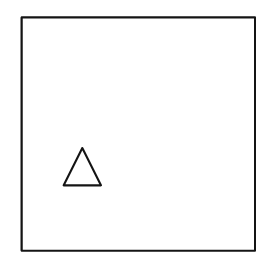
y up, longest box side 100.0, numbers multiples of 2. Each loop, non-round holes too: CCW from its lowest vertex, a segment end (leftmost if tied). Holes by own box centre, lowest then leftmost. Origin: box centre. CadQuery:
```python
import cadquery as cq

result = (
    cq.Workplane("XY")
    .moveTo(-50.0, -50.0)
    .lineTo(50.0, -50.0)
    .lineTo(50.0, 50.0)
    .lineTo(-50.0, 50.0)
    .close()
    .moveTo(-32.0, -22.0)
    .lineTo(-16.0, -22.0)
    .lineTo(-24.0, -6.0)
    .close()
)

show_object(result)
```